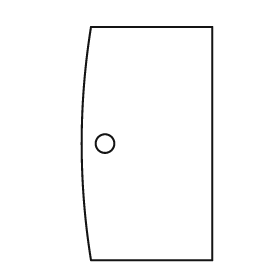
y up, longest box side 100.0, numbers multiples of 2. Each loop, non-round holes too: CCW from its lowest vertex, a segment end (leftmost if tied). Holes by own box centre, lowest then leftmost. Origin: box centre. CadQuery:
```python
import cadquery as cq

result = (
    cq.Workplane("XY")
    .moveTo(-24.0, -50.0)
    .lineTo(28.0, -50.0)
    .lineTo(28.0, 50.0)
    .lineTo(-24.0, 50.0)
    .threePointArc((-28.0, 0.0), (-24.0, -50.0))
    .close()
    .moveTo(-18.0, 0.0)
    .circle(4.0)
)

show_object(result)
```